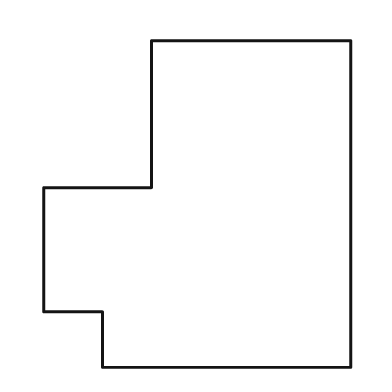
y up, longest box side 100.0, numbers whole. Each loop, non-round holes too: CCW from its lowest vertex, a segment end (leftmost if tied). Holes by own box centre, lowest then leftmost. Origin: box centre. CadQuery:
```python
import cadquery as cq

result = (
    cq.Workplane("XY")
    .moveTo(-29.0, -50.0)
    .lineTo(47.0, -50.0)
    .lineTo(47.0, 50.0)
    .lineTo(-14.0, 50.0)
    .lineTo(-14.0, 5.0)
    .lineTo(-47.0, 5.0)
    .lineTo(-47.0, -33.0)
    .lineTo(-29.0, -33.0)
    .close()
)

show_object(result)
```